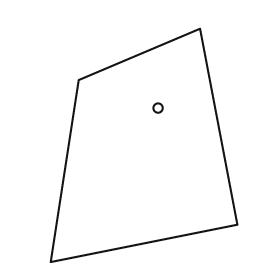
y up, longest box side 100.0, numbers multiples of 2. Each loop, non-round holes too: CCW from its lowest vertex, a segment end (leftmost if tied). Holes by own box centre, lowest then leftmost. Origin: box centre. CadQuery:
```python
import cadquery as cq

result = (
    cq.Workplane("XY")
    .moveTo(-40.0, -50.0)
    .lineTo(40.0, -34.0)
    .lineTo(24.0, 50.0)
    .lineTo(-28.0, 28.0)
    .close()
    .moveTo(6.0, 16.0)
    .circle(2.0)
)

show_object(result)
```